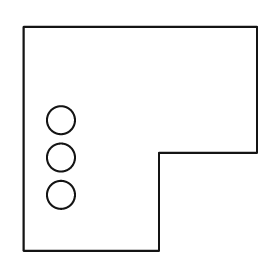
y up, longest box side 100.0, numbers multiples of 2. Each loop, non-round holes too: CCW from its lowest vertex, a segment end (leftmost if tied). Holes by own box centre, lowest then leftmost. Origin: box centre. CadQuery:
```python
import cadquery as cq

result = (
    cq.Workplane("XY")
    .moveTo(-50.0, -48.0)
    .lineTo(8.0, -48.0)
    .lineTo(8.0, -6.0)
    .lineTo(50.0, -6.0)
    .lineTo(50.0, 48.0)
    .lineTo(-50.0, 48.0)
    .close()
    .moveTo(-34.0, -24.0)
    .circle(6.0)
    .moveTo(-34.0, -8.0)
    .circle(6.0)
    .moveTo(-34.0, 8.0)
    .circle(6.0)
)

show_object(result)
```